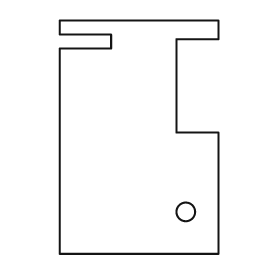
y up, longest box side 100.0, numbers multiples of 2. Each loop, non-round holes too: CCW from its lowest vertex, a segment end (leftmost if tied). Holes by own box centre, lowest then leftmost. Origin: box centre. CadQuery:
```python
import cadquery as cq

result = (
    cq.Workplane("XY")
    .moveTo(-34.0, -50.0)
    .lineTo(34.0, -50.0)
    .lineTo(34.0, 2.0)
    .lineTo(16.0, 2.0)
    .lineTo(16.0, 42.0)
    .lineTo(34.0, 42.0)
    .lineTo(34.0, 50.0)
    .lineTo(-34.0, 50.0)
    .lineTo(-34.0, 44.0)
    .lineTo(-12.0, 44.0)
    .lineTo(-12.0, 38.0)
    .lineTo(-34.0, 38.0)
    .close()
    .moveTo(20.0, -32.0)
    .circle(4.0)
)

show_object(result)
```